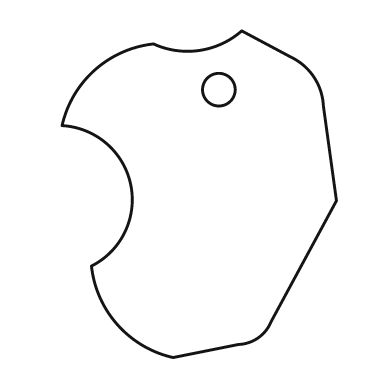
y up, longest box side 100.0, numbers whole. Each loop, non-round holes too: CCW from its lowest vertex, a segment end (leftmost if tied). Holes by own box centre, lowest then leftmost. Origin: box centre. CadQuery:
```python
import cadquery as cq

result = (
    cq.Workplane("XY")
    .moveTo(-8.0, -50.0)
    .lineTo(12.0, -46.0)
    .threePointArc((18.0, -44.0), (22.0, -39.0))
    .lineTo(42.0, -2.0)
    .lineTo(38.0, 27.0)
    .threePointArc((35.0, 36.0), (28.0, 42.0))
    .lineTo(13.0, 50.0)
    .threePointArc((0.0, 44.0), (-14.0, 46.0))
    .threePointArc((-32.0, 38.0), (-42.0, 21.0))
    .threePointArc((-21.0, 3.0), (-33.0, -22.0))
    .threePointArc((-25.0, -40.0), (-8.0, -50.0))
    .close()
    .moveTo(6.0, 32.0)
    .circle(5.0)
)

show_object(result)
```